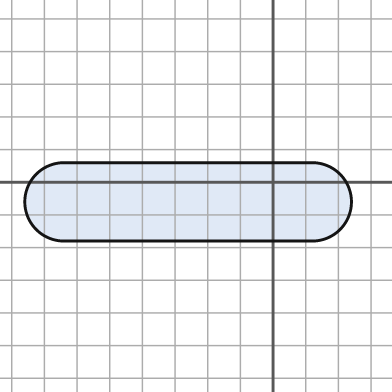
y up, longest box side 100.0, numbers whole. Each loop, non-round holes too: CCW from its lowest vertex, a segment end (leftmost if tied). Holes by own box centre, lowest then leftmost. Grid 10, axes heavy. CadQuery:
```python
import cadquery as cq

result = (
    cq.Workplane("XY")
    .moveTo(-64.0, -18.0)
    .lineTo(12.0, -18.0)
    .threePointArc((24.0, -6.0), (12.0, 6.0))
    .lineTo(-64.0, 6.0)
    .threePointArc((-76.0, -6.0), (-64.0, -18.0))
    .close()
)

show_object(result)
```